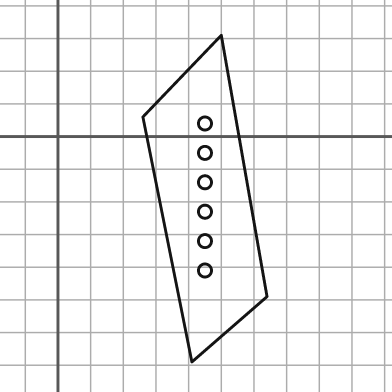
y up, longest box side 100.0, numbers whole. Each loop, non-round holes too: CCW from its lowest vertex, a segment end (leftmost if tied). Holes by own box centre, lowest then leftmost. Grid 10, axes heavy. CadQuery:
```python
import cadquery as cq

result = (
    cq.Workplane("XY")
    .moveTo(41.0, -69.0)
    .lineTo(64.0, -49.0)
    .lineTo(50.0, 31.0)
    .lineTo(26.0, 6.0)
    .close()
    .moveTo(45.0, -41.0)
    .circle(2.0)
    .moveTo(45.0, -32.0)
    .circle(2.0)
    .moveTo(45.0, -23.0)
    .circle(2.0)
    .moveTo(45.0, -14.0)
    .circle(2.0)
    .moveTo(45.0, -5.0)
    .circle(2.0)
    .moveTo(45.0, 4.0)
    .circle(2.0)
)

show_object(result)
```